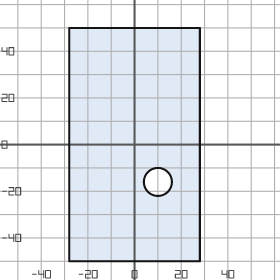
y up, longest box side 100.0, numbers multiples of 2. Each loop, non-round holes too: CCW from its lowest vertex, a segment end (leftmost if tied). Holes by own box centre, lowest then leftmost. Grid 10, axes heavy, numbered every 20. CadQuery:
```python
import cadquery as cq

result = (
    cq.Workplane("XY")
    .moveTo(-28.0, -50.0)
    .lineTo(28.0, -50.0)
    .lineTo(28.0, 50.0)
    .lineTo(-28.0, 50.0)
    .close()
    .moveTo(10.0, -16.0)
    .circle(6.0)
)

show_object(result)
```